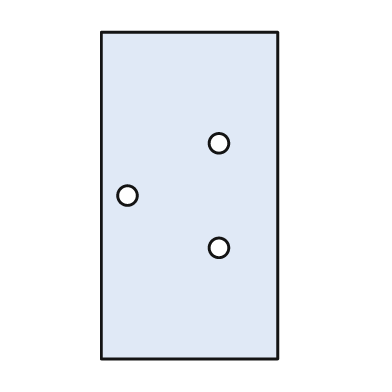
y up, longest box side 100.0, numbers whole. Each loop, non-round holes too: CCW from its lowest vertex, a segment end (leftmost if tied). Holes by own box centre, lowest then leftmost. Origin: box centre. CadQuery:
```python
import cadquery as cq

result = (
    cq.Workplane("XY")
    .moveTo(-27.0, -50.0)
    .lineTo(27.0, -50.0)
    .lineTo(27.0, 50.0)
    .lineTo(-27.0, 50.0)
    .close()
    .moveTo(9.0, -16.0)
    .circle(3.0)
    .moveTo(-19.0, 0.0)
    .circle(3.0)
    .moveTo(9.0, 16.0)
    .circle(3.0)
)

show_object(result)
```